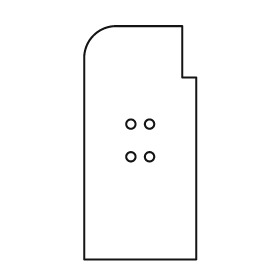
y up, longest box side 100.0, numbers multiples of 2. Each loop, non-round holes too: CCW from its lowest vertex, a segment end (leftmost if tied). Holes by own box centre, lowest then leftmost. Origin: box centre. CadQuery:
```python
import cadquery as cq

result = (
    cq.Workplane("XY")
    .moveTo(-24.0, -50.0)
    .lineTo(24.0, -50.0)
    .lineTo(24.0, 28.0)
    .lineTo(18.0, 28.0)
    .lineTo(18.0, 50.0)
    .lineTo(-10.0, 50.0)
    .threePointArc((-20.0, 46.0), (-24.0, 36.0))
    .close()
    .moveTo(-4.0, -6.0)
    .circle(2.0)
    .moveTo(4.0, -6.0)
    .circle(2.0)
    .moveTo(-4.0, 8.0)
    .circle(2.0)
    .moveTo(4.0, 8.0)
    .circle(2.0)
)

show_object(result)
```